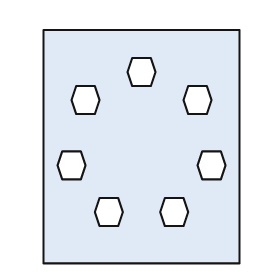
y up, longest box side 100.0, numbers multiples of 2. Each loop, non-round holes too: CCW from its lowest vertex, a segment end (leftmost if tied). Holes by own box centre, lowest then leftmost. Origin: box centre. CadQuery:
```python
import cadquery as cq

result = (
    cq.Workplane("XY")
    .moveTo(-42.0, -50.0)
    .lineTo(42.0, -50.0)
    .lineTo(42.0, 50.0)
    .lineTo(-42.0, 50.0)
    .close()
    .moveTo(-18.0, -34.0)
    .lineTo(-10.0, -34.0)
    .lineTo(-8.0, -28.0)
    .lineTo(-10.0, -22.0)
    .lineTo(-18.0, -22.0)
    .lineTo(-20.0, -28.0)
    .close()
    .moveTo(10.0, -34.0)
    .lineTo(18.0, -34.0)
    .lineTo(20.0, -28.0)
    .lineTo(18.0, -22.0)
    .lineTo(10.0, -22.0)
    .lineTo(8.0, -28.0)
    .close()
    .moveTo(-34.0, -14.0)
    .lineTo(-26.0, -14.0)
    .lineTo(-24.0, -8.0)
    .lineTo(-26.0, -2.0)
    .lineTo(-34.0, -2.0)
    .lineTo(-36.0, -8.0)
    .close()
    .moveTo(26.0, -14.0)
    .lineTo(34.0, -14.0)
    .lineTo(36.0, -8.0)
    .lineTo(34.0, -2.0)
    .lineTo(26.0, -2.0)
    .lineTo(24.0, -8.0)
    .close()
    .moveTo(-28.0, 14.0)
    .lineTo(-20.0, 14.0)
    .lineTo(-18.0, 20.0)
    .lineTo(-20.0, 26.0)
    .lineTo(-28.0, 26.0)
    .lineTo(-30.0, 20.0)
    .close()
    .moveTo(20.0, 14.0)
    .lineTo(28.0, 14.0)
    .lineTo(30.0, 20.0)
    .lineTo(28.0, 26.0)
    .lineTo(20.0, 26.0)
    .lineTo(18.0, 20.0)
    .close()
    .moveTo(-4.0, 26.0)
    .lineTo(4.0, 26.0)
    .lineTo(6.0, 32.0)
    .lineTo(4.0, 38.0)
    .lineTo(-4.0, 38.0)
    .lineTo(-6.0, 32.0)
    .close()
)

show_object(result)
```